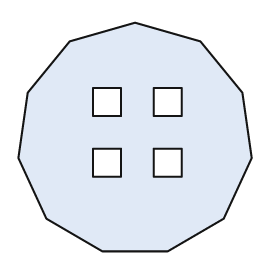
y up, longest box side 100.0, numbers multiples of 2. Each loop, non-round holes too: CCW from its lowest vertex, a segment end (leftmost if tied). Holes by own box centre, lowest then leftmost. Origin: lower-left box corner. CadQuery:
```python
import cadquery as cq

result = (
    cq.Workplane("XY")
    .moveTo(36.0, 0.0)
    .lineTo(64.0, 0.0)
    .lineTo(88.0, 14.0)
    .lineTo(100.0, 40.0)
    .lineTo(96.0, 68.0)
    .lineTo(78.0, 90.0)
    .lineTo(50.0, 98.0)
    .lineTo(22.0, 90.0)
    .lineTo(4.0, 68.0)
    .lineTo(0.0, 40.0)
    .lineTo(12.0, 14.0)
    .close()
    .moveTo(32.0, 32.0)
    .lineTo(44.0, 32.0)
    .lineTo(44.0, 44.0)
    .lineTo(32.0, 44.0)
    .close()
    .moveTo(58.0, 32.0)
    .lineTo(70.0, 32.0)
    .lineTo(70.0, 44.0)
    .lineTo(58.0, 44.0)
    .close()
    .moveTo(32.0, 58.0)
    .lineTo(44.0, 58.0)
    .lineTo(44.0, 70.0)
    .lineTo(32.0, 70.0)
    .close()
    .moveTo(58.0, 58.0)
    .lineTo(70.0, 58.0)
    .lineTo(70.0, 70.0)
    .lineTo(58.0, 70.0)
    .close()
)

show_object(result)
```